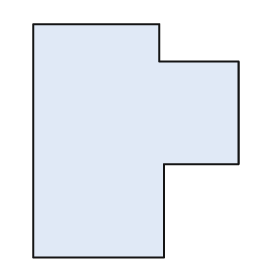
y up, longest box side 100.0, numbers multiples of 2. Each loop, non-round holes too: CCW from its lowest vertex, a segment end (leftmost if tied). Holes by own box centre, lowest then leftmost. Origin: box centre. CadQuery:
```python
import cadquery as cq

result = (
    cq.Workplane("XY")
    .moveTo(-44.0, -50.0)
    .lineTo(12.0, -50.0)
    .lineTo(12.0, -10.0)
    .lineTo(44.0, -10.0)
    .lineTo(44.0, 34.0)
    .lineTo(10.0, 34.0)
    .lineTo(10.0, 50.0)
    .lineTo(-44.0, 50.0)
    .close()
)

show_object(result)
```